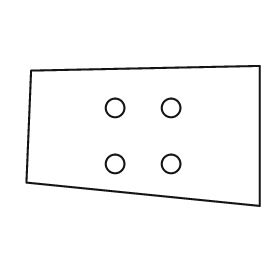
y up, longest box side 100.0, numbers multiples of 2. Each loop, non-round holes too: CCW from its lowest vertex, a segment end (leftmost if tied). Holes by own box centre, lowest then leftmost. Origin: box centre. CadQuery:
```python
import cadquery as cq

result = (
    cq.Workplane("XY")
    .moveTo(50.0, -30.0)
    .lineTo(50.0, 30.0)
    .lineTo(-48.0, 28.0)
    .lineTo(-50.0, -20.0)
    .close()
    .moveTo(-12.0, -12.0)
    .circle(4.0)
    .moveTo(12.0, -12.0)
    .circle(4.0)
    .moveTo(-12.0, 12.0)
    .circle(4.0)
    .moveTo(12.0, 12.0)
    .circle(4.0)
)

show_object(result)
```